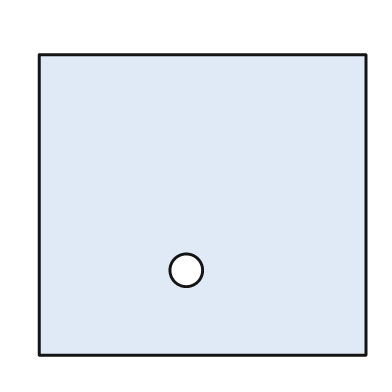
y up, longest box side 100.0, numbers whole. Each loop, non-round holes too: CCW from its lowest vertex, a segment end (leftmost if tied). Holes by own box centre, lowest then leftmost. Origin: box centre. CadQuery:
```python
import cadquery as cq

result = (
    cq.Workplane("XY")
    .moveTo(-50.0, -46.0)
    .lineTo(50.0, -46.0)
    .lineTo(50.0, 46.0)
    .lineTo(-50.0, 46.0)
    .close()
    .moveTo(-5.0, -20.0)
    .circle(5.0)
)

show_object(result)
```